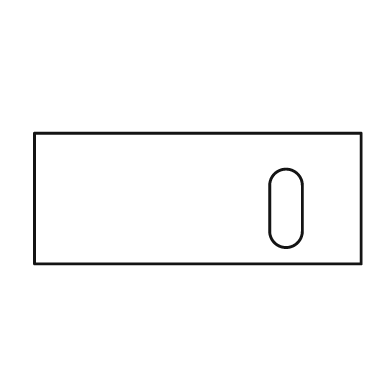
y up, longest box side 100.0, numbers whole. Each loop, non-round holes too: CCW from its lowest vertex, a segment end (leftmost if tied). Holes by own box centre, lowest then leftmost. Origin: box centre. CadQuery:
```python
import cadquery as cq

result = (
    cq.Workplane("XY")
    .moveTo(-50.0, -20.0)
    .lineTo(50.0, -20.0)
    .lineTo(50.0, 20.0)
    .lineTo(-50.0, 20.0)
    .close()
    .moveTo(22.0, -10.0)
    .threePointArc((27.0, -15.0), (32.0, -10.0))
    .lineTo(32.0, 4.0)
    .threePointArc((27.0, 9.0), (22.0, 4.0))
    .close()
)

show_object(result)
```